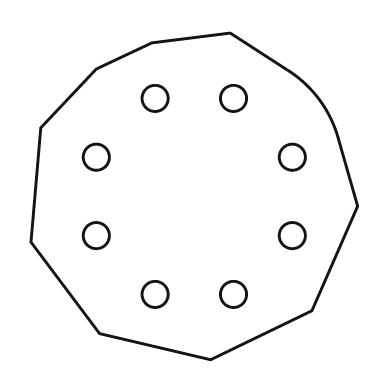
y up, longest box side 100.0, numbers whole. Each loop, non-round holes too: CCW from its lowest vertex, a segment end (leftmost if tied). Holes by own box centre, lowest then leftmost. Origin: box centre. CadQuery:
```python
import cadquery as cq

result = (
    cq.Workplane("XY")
    .moveTo(5.0, -50.0)
    .lineTo(36.0, -35.0)
    .lineTo(50.0, -3.0)
    .lineTo(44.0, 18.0)
    .threePointArc((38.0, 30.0), (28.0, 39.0))
    .lineTo(11.0, 50.0)
    .lineTo(-13.0, 47.0)
    .lineTo(-30.0, 39.0)
    .lineTo(-47.0, 21.0)
    .lineTo(-50.0, -14.0)
    .lineTo(-29.0, -42.0)
    .close()
    .moveTo(-12.0, -30.0)
    .circle(4.0)
    .moveTo(12.0, -30.0)
    .circle(4.0)
    .moveTo(-30.0, -12.0)
    .circle(4.0)
    .moveTo(30.0, -12.0)
    .circle(4.0)
    .moveTo(-30.0, 12.0)
    .circle(4.0)
    .moveTo(30.0, 12.0)
    .circle(4.0)
    .moveTo(-12.0, 30.0)
    .circle(4.0)
    .moveTo(12.0, 30.0)
    .circle(4.0)
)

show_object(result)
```